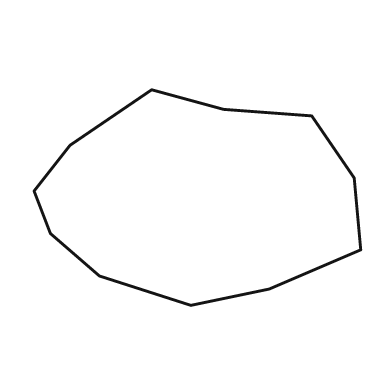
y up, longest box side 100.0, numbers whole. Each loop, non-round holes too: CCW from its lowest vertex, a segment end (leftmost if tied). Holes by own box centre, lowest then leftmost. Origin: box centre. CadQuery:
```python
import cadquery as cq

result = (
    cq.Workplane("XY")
    .moveTo(-2.0, -33.0)
    .lineTo(22.0, -28.0)
    .lineTo(50.0, -16.0)
    .lineTo(48.0, 6.0)
    .lineTo(35.0, 25.0)
    .lineTo(8.0, 27.0)
    .lineTo(-14.0, 33.0)
    .lineTo(-39.0, 16.0)
    .lineTo(-50.0, 2.0)
    .lineTo(-45.0, -11.0)
    .lineTo(-30.0, -24.0)
    .close()
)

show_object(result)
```